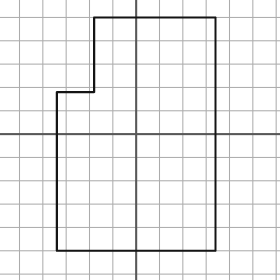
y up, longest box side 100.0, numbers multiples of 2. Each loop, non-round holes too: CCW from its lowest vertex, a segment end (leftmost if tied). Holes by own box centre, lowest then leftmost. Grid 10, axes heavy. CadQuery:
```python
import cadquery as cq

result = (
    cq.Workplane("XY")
    .moveTo(-34.0, -50.0)
    .lineTo(34.0, -50.0)
    .lineTo(34.0, 50.0)
    .lineTo(-18.0, 50.0)
    .lineTo(-18.0, 18.0)
    .lineTo(-34.0, 18.0)
    .close()
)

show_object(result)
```